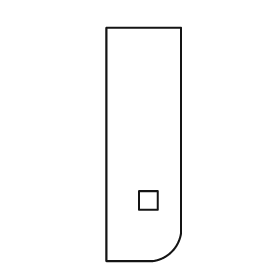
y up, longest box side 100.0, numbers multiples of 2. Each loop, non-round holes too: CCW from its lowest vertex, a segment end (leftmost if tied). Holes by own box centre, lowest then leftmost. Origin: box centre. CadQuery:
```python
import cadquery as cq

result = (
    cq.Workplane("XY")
    .moveTo(-16.0, -50.0)
    .lineTo(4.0, -50.0)
    .threePointArc((12.0, -46.0), (16.0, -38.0))
    .lineTo(16.0, 50.0)
    .lineTo(-16.0, 50.0)
    .close()
    .moveTo(-2.0, -28.0)
    .lineTo(6.0, -28.0)
    .lineTo(6.0, -20.0)
    .lineTo(-2.0, -20.0)
    .close()
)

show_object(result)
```